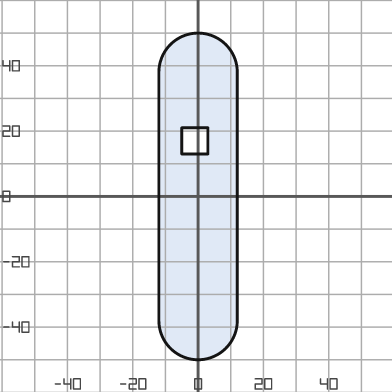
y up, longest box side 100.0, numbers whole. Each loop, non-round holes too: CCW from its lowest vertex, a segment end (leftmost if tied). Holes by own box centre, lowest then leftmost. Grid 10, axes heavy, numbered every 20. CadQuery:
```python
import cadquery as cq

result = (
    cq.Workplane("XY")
    .moveTo(-12.0, -38.0)
    .threePointArc((0.0, -50.0), (12.0, -38.0))
    .lineTo(12.0, 38.0)
    .threePointArc((0.0, 50.0), (-12.0, 38.0))
    .close()
    .moveTo(-5.0, 13.0)
    .lineTo(3.0, 13.0)
    .lineTo(3.0, 21.0)
    .lineTo(-5.0, 21.0)
    .close()
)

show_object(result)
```